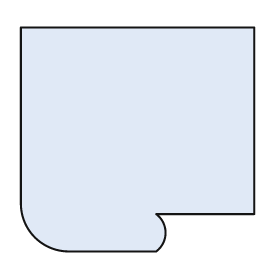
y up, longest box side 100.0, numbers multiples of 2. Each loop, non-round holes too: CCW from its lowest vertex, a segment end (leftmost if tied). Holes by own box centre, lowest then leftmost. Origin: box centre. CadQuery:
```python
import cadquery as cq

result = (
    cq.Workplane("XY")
    .moveTo(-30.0, -48.0)
    .lineTo(8.0, -48.0)
    .threePointArc((12.0, -40.0), (8.0, -32.0))
    .lineTo(50.0, -32.0)
    .lineTo(50.0, 48.0)
    .lineTo(-50.0, 48.0)
    .lineTo(-50.0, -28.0)
    .threePointArc((-44.0, -42.0), (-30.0, -48.0))
    .close()
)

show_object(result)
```